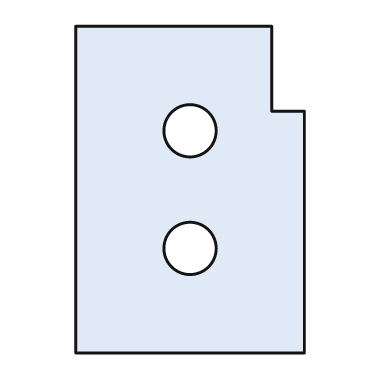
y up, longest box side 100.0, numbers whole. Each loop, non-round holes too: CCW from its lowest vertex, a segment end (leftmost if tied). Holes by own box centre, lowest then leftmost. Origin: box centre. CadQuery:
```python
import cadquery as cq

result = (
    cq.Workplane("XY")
    .moveTo(-35.0, -50.0)
    .lineTo(35.0, -50.0)
    .lineTo(35.0, 24.0)
    .lineTo(25.0, 24.0)
    .lineTo(25.0, 50.0)
    .lineTo(-35.0, 50.0)
    .close()
    .moveTo(0.0, -18.0)
    .circle(8.0)
    .moveTo(0.0, 18.0)
    .circle(8.0)
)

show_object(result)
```